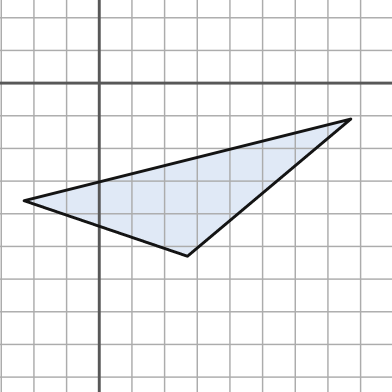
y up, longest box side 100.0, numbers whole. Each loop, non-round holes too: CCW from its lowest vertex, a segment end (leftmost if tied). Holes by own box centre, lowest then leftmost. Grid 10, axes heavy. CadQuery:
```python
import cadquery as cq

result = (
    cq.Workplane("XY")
    .moveTo(27.0, -53.0)
    .lineTo(77.0, -11.0)
    .lineTo(-23.0, -36.0)
    .close()
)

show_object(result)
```